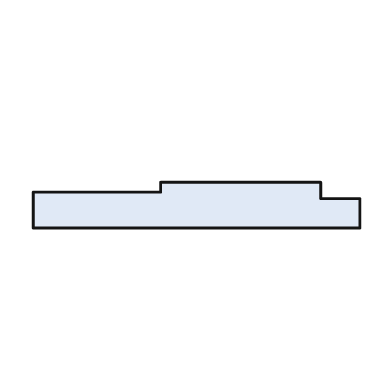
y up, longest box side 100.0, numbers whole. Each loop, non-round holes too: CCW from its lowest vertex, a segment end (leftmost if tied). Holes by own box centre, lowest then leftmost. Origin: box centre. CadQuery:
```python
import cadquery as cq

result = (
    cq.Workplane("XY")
    .moveTo(-50.0, -7.0)
    .lineTo(50.0, -7.0)
    .lineTo(50.0, 2.0)
    .lineTo(38.0, 2.0)
    .lineTo(38.0, 7.0)
    .lineTo(-11.0, 7.0)
    .lineTo(-11.0, 4.0)
    .lineTo(-50.0, 4.0)
    .close()
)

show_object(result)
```